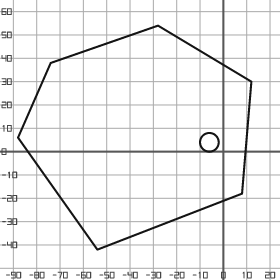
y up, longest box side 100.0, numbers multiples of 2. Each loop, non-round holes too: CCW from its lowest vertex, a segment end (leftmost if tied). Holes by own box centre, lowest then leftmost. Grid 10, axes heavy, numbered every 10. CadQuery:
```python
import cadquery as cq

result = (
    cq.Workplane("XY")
    .moveTo(-54.0, -42.0)
    .lineTo(8.0, -18.0)
    .lineTo(12.0, 30.0)
    .lineTo(-28.0, 54.0)
    .lineTo(-74.0, 38.0)
    .lineTo(-88.0, 6.0)
    .close()
    .moveTo(-6.0, 4.0)
    .circle(4.0)
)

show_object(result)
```